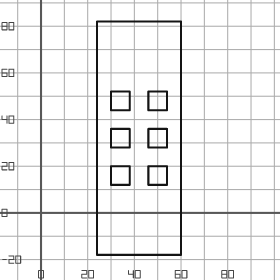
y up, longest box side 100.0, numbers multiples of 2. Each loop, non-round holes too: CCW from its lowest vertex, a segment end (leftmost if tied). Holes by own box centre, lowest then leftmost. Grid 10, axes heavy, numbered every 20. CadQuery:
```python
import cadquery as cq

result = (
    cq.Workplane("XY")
    .moveTo(24.0, -18.0)
    .lineTo(60.0, -18.0)
    .lineTo(60.0, 82.0)
    .lineTo(24.0, 82.0)
    .close()
    .moveTo(30.0, 12.0)
    .lineTo(38.0, 12.0)
    .lineTo(38.0, 20.0)
    .lineTo(30.0, 20.0)
    .close()
    .moveTo(46.0, 12.0)
    .lineTo(54.0, 12.0)
    .lineTo(54.0, 20.0)
    .lineTo(46.0, 20.0)
    .close()
    .moveTo(30.0, 28.0)
    .lineTo(38.0, 28.0)
    .lineTo(38.0, 36.0)
    .lineTo(30.0, 36.0)
    .close()
    .moveTo(46.0, 28.0)
    .lineTo(54.0, 28.0)
    .lineTo(54.0, 36.0)
    .lineTo(46.0, 36.0)
    .close()
    .moveTo(30.0, 44.0)
    .lineTo(38.0, 44.0)
    .lineTo(38.0, 52.0)
    .lineTo(30.0, 52.0)
    .close()
    .moveTo(46.0, 44.0)
    .lineTo(54.0, 44.0)
    .lineTo(54.0, 52.0)
    .lineTo(46.0, 52.0)
    .close()
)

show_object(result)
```